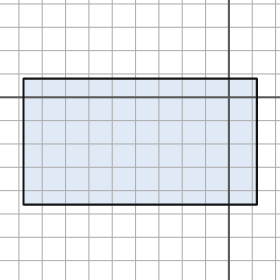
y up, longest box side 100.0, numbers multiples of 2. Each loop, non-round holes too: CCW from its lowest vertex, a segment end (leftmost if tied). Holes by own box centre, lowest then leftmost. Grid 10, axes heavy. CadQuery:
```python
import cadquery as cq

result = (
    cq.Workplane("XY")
    .moveTo(-88.0, -46.0)
    .lineTo(12.0, -46.0)
    .lineTo(12.0, 8.0)
    .lineTo(-88.0, 8.0)
    .close()
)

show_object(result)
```